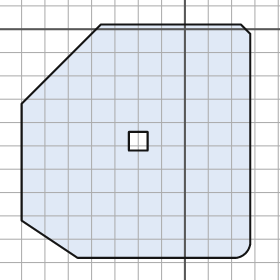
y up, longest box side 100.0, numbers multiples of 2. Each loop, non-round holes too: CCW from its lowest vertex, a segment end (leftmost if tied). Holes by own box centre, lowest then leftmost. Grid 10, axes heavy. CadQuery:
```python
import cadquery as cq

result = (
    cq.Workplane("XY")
    .moveTo(-46.0, -98.0)
    .lineTo(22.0, -98.0)
    .threePointArc((26.0, -96.0), (28.0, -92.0))
    .lineTo(28.0, -2.0)
    .lineTo(24.0, 2.0)
    .lineTo(-36.0, 2.0)
    .lineTo(-70.0, -32.0)
    .lineTo(-70.0, -82.0)
    .close()
    .moveTo(-24.0, -52.0)
    .lineTo(-16.0, -52.0)
    .lineTo(-16.0, -44.0)
    .lineTo(-24.0, -44.0)
    .close()
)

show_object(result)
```